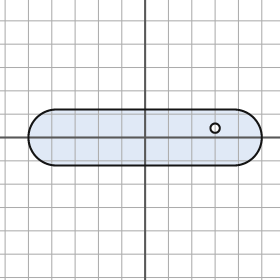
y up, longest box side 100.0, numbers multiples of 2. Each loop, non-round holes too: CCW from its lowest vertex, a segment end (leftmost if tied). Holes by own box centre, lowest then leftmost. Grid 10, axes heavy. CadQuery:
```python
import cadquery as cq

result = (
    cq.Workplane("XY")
    .moveTo(-38.0, -12.0)
    .lineTo(38.0, -12.0)
    .threePointArc((50.0, 0.0), (38.0, 12.0))
    .lineTo(-38.0, 12.0)
    .threePointArc((-50.0, 0.0), (-38.0, -12.0))
    .close()
    .moveTo(30.0, 4.0)
    .circle(2.0)
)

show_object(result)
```